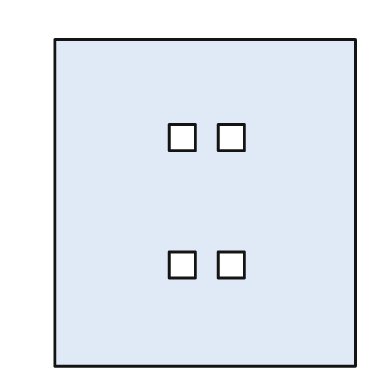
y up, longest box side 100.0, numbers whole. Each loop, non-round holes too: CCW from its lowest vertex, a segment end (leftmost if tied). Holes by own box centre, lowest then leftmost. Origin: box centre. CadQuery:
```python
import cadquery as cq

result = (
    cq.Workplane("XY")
    .moveTo(-46.0, -50.0)
    .lineTo(46.0, -50.0)
    .lineTo(46.0, 50.0)
    .lineTo(-46.0, 50.0)
    .close()
    .moveTo(-11.0, -23.0)
    .lineTo(-3.0, -23.0)
    .lineTo(-3.0, -15.0)
    .lineTo(-11.0, -15.0)
    .close()
    .moveTo(4.0, -23.0)
    .lineTo(12.0, -23.0)
    .lineTo(12.0, -15.0)
    .lineTo(4.0, -15.0)
    .close()
    .moveTo(-11.0, 16.0)
    .lineTo(-3.0, 16.0)
    .lineTo(-3.0, 24.0)
    .lineTo(-11.0, 24.0)
    .close()
    .moveTo(4.0, 16.0)
    .lineTo(12.0, 16.0)
    .lineTo(12.0, 24.0)
    .lineTo(4.0, 24.0)
    .close()
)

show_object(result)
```